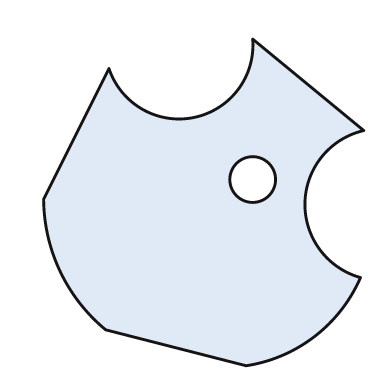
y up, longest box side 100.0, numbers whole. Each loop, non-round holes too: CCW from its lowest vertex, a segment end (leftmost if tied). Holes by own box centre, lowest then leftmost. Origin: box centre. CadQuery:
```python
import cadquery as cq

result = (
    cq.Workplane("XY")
    .moveTo(13.0, -50.0)
    .threePointArc((34.0, -41.0), (48.0, -23.0))
    .threePointArc((31.0, 0.0), (49.0, 22.0))
    .lineTo(15.0, 50.0)
    .threePointArc((-3.0, 26.0), (-29.0, 41.0))
    .lineTo(-49.0, 1.0)
    .threePointArc((-44.0, -21.0), (-30.0, -39.0))
    .close()
    .moveTo(15.0, 7.0)
    .circle(7.0)
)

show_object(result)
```